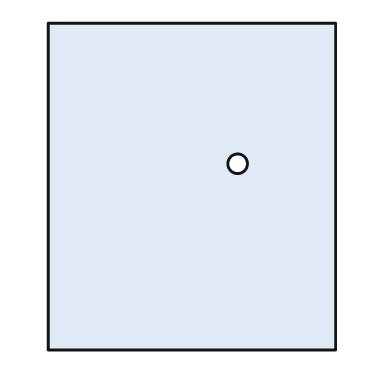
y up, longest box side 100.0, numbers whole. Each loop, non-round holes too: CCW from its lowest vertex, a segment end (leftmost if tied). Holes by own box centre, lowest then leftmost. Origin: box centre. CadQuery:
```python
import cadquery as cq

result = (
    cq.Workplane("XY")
    .moveTo(-44.0, -50.0)
    .lineTo(44.0, -50.0)
    .lineTo(44.0, 50.0)
    .lineTo(-44.0, 50.0)
    .close()
    .moveTo(14.0, 7.0)
    .circle(3.0)
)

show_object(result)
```